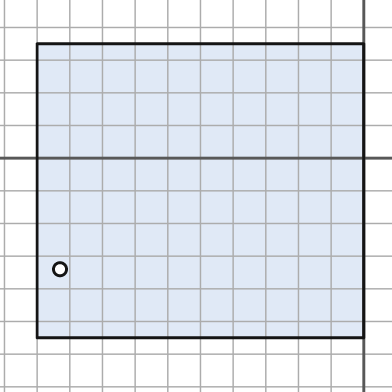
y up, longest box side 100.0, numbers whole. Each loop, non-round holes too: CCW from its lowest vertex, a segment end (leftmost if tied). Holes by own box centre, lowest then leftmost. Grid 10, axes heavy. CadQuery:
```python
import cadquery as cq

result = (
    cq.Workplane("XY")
    .moveTo(-100.0, -55.0)
    .lineTo(0.0, -55.0)
    .lineTo(0.0, 35.0)
    .lineTo(-100.0, 35.0)
    .close()
    .moveTo(-93.0, -34.0)
    .circle(2.0)
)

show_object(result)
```